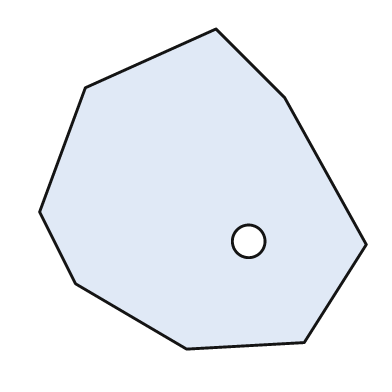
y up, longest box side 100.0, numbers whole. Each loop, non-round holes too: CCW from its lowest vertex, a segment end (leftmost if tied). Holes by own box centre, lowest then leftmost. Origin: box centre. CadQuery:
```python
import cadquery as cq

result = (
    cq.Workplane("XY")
    .moveTo(-5.0, -49.0)
    .lineTo(31.0, -47.0)
    .lineTo(50.0, -17.0)
    .lineTo(25.0, 28.0)
    .lineTo(4.0, 49.0)
    .lineTo(-36.0, 31.0)
    .lineTo(-50.0, -7.0)
    .lineTo(-39.0, -29.0)
    .close()
    .moveTo(14.0, -16.0)
    .circle(5.0)
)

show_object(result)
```